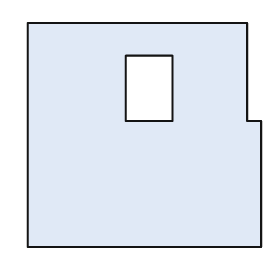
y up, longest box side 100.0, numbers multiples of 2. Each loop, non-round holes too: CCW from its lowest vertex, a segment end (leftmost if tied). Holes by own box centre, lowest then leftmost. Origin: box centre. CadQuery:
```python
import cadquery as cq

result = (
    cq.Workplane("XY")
    .moveTo(-50.0, -48.0)
    .lineTo(50.0, -48.0)
    .lineTo(50.0, 6.0)
    .lineTo(44.0, 6.0)
    .lineTo(44.0, 48.0)
    .lineTo(-50.0, 48.0)
    .close()
    .moveTo(-8.0, 6.0)
    .lineTo(12.0, 6.0)
    .lineTo(12.0, 34.0)
    .lineTo(-8.0, 34.0)
    .close()
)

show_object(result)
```